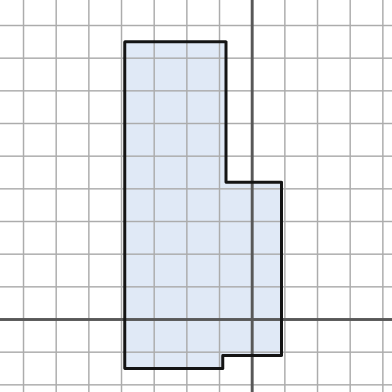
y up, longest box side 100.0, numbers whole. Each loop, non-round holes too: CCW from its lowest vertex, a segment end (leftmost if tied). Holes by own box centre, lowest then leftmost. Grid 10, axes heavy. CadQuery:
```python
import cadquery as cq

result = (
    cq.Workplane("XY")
    .moveTo(-39.0, -15.0)
    .lineTo(-9.0, -15.0)
    .lineTo(-9.0, -11.0)
    .lineTo(9.0, -11.0)
    .lineTo(9.0, 42.0)
    .lineTo(-8.0, 42.0)
    .lineTo(-8.0, 85.0)
    .lineTo(-39.0, 85.0)
    .close()
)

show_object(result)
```